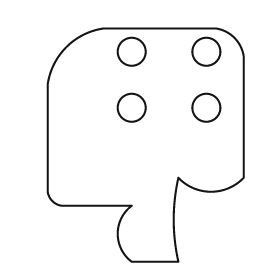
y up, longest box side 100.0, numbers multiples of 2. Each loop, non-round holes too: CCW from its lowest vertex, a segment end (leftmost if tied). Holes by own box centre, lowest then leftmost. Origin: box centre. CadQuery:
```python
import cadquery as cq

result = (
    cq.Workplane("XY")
    .moveTo(-6.0, -50.0)
    .lineTo(14.0, -50.0)
    .threePointArc((12.0, -32.0), (14.0, -14.0))
    .threePointArc((28.0, -20.0), (42.0, -14.0))
    .lineTo(42.0, 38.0)
    .threePointArc((38.0, 46.0), (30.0, 50.0))
    .lineTo(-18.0, 50.0)
    .threePointArc((-34.0, 42.0), (-42.0, 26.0))
    .lineTo(-42.0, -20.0)
    .threePointArc((-40.0, -24.0), (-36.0, -26.0))
    .lineTo(-6.0, -26.0)
    .threePointArc((-12.0, -38.0), (-6.0, -50.0))
    .close()
    .moveTo(-6.0, 16.0)
    .circle(6.0)
    .moveTo(26.0, 16.0)
    .circle(6.0)
    .moveTo(-6.0, 40.0)
    .circle(6.0)
    .moveTo(26.0, 40.0)
    .circle(6.0)
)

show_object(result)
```